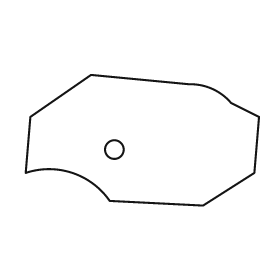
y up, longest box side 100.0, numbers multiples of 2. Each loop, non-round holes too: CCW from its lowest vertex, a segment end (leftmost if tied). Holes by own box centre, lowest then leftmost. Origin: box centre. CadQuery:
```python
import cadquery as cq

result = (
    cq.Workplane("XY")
    .moveTo(26.0, -28.0)
    .lineTo(48.0, -14.0)
    .lineTo(50.0, 10.0)
    .lineTo(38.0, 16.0)
    .threePointArc((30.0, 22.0), (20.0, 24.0))
    .lineTo(-22.0, 28.0)
    .lineTo(-48.0, 10.0)
    .lineTo(-50.0, -14.0)
    .threePointArc((-30.0, -14.0), (-14.0, -26.0))
    .close()
    .moveTo(-12.0, -4.0)
    .circle(4.0)
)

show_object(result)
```